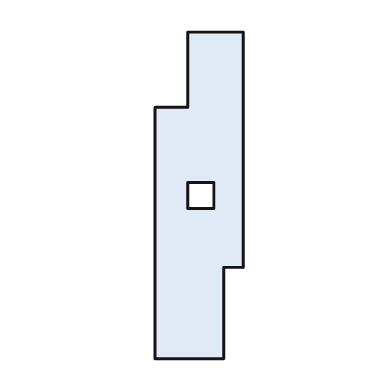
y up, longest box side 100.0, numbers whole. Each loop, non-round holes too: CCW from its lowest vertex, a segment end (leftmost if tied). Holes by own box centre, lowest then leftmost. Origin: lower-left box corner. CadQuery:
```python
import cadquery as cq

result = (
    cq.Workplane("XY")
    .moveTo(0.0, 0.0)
    .lineTo(21.0, 0.0)
    .lineTo(21.0, 28.0)
    .lineTo(27.0, 28.0)
    .lineTo(27.0, 100.0)
    .lineTo(10.0, 100.0)
    .lineTo(10.0, 77.0)
    .lineTo(0.0, 77.0)
    .close()
    .moveTo(10.0, 46.0)
    .lineTo(18.0, 46.0)
    .lineTo(18.0, 54.0)
    .lineTo(10.0, 54.0)
    .close()
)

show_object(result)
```